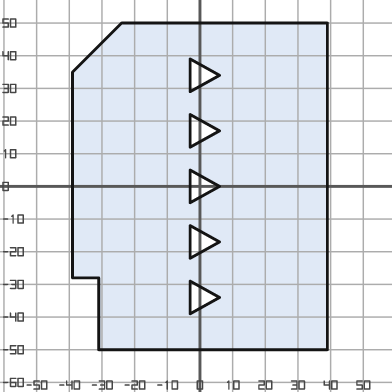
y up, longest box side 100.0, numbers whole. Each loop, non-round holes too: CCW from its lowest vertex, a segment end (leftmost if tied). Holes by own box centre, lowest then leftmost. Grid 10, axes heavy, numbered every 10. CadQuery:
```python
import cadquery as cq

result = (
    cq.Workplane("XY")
    .moveTo(-31.0, -50.0)
    .lineTo(39.0, -50.0)
    .lineTo(39.0, 50.0)
    .lineTo(-24.0, 50.0)
    .lineTo(-39.0, 35.0)
    .lineTo(-39.0, -28.0)
    .lineTo(-31.0, -28.0)
    .close()
    .moveTo(-3.0, -39.0)
    .lineTo(6.0, -34.0)
    .lineTo(-3.0, -29.0)
    .close()
    .moveTo(-3.0, -22.0)
    .lineTo(6.0, -17.0)
    .lineTo(-3.0, -12.0)
    .close()
    .moveTo(-3.0, -5.0)
    .lineTo(6.0, 0.0)
    .lineTo(-3.0, 5.0)
    .close()
    .moveTo(-3.0, 12.0)
    .lineTo(6.0, 17.0)
    .lineTo(-3.0, 22.0)
    .close()
    .moveTo(-3.0, 29.0)
    .lineTo(6.0, 34.0)
    .lineTo(-3.0, 39.0)
    .close()
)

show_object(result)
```